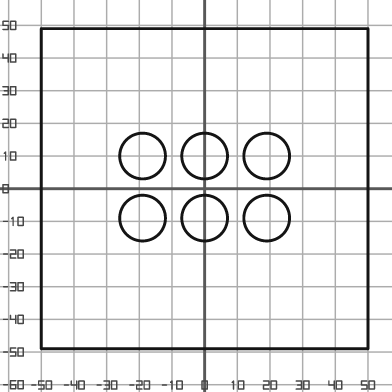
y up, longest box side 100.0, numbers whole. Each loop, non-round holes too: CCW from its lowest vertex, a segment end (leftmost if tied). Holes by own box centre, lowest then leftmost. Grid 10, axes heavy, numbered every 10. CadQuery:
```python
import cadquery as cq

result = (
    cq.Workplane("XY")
    .moveTo(-50.0, -49.0)
    .lineTo(50.0, -49.0)
    .lineTo(50.0, 49.0)
    .lineTo(-50.0, 49.0)
    .close()
    .moveTo(-19.0, -9.0)
    .circle(7.0)
    .moveTo(0.0, -9.0)
    .circle(7.0)
    .moveTo(19.0, -9.0)
    .circle(7.0)
    .moveTo(-19.0, 10.0)
    .circle(7.0)
    .moveTo(0.0, 10.0)
    .circle(7.0)
    .moveTo(19.0, 10.0)
    .circle(7.0)
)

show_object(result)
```